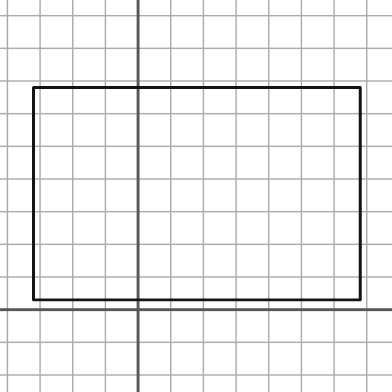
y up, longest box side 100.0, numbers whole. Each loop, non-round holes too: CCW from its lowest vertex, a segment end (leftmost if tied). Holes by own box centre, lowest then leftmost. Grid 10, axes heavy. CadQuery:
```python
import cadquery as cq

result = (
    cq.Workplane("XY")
    .moveTo(-32.0, 3.0)
    .lineTo(68.0, 3.0)
    .lineTo(68.0, 68.0)
    .lineTo(-32.0, 68.0)
    .close()
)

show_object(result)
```